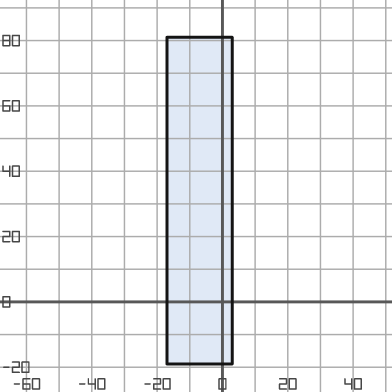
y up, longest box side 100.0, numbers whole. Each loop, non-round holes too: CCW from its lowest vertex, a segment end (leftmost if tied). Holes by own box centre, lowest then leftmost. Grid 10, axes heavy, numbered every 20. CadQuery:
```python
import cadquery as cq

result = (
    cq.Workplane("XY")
    .moveTo(-17.0, -19.0)
    .lineTo(3.0, -19.0)
    .lineTo(3.0, 81.0)
    .lineTo(-17.0, 81.0)
    .close()
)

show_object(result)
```